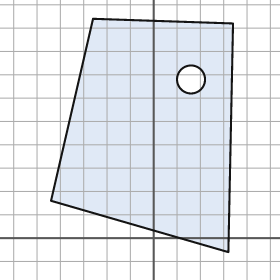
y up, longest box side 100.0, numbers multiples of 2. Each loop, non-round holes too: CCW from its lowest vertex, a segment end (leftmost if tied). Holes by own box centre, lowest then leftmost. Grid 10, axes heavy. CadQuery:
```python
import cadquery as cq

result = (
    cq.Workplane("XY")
    .moveTo(32.0, -6.0)
    .lineTo(34.0, 92.0)
    .lineTo(-26.0, 94.0)
    .lineTo(-44.0, 16.0)
    .close()
    .moveTo(16.0, 68.0)
    .circle(6.0)
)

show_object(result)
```